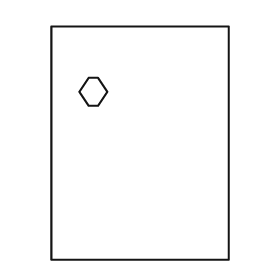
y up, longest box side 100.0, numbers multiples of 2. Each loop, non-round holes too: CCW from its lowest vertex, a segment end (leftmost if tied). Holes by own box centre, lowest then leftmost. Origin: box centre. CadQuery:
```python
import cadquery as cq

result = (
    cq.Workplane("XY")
    .moveTo(-38.0, -50.0)
    .lineTo(38.0, -50.0)
    .lineTo(38.0, 50.0)
    .lineTo(-38.0, 50.0)
    .close()
    .moveTo(-22.0, 16.0)
    .lineTo(-18.0, 16.0)
    .lineTo(-14.0, 22.0)
    .lineTo(-18.0, 28.0)
    .lineTo(-22.0, 28.0)
    .lineTo(-26.0, 22.0)
    .close()
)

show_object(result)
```